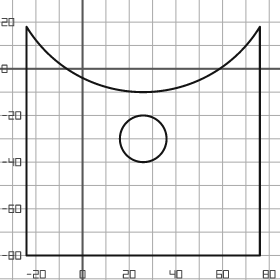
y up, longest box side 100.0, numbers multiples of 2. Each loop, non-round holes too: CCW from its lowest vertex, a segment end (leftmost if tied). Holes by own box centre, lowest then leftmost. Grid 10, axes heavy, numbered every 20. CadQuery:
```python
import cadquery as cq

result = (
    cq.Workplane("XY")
    .moveTo(-24.0, -80.0)
    .lineTo(76.0, -80.0)
    .lineTo(76.0, 18.0)
    .threePointArc((26.0, -10.0), (-24.0, 18.0))
    .close()
    .moveTo(26.0, -30.0)
    .circle(10.0)
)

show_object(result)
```